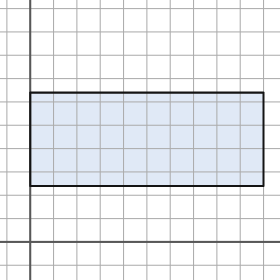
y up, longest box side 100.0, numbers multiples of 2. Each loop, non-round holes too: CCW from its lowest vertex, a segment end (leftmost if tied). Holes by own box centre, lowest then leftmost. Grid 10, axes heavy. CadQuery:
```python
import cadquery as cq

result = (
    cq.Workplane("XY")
    .moveTo(0.0, 24.0)
    .lineTo(100.0, 24.0)
    .lineTo(100.0, 64.0)
    .lineTo(0.0, 64.0)
    .close()
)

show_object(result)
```